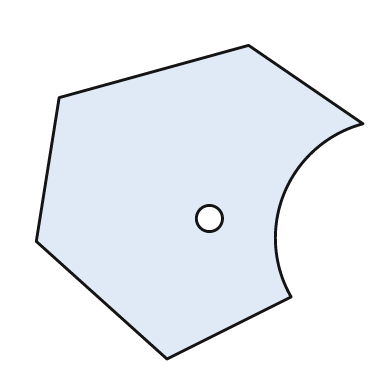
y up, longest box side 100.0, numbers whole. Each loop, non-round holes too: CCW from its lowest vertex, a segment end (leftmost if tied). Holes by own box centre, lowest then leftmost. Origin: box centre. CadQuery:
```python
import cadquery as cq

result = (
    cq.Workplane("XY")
    .moveTo(-10.0, -48.0)
    .lineTo(28.0, -29.0)
    .threePointArc((26.0, 3.0), (50.0, 24.0))
    .lineTo(15.0, 48.0)
    .lineTo(-43.0, 32.0)
    .lineTo(-50.0, -12.0)
    .close()
    .moveTo(3.0, -5.0)
    .circle(4.0)
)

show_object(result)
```